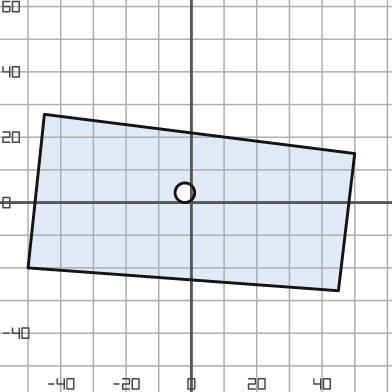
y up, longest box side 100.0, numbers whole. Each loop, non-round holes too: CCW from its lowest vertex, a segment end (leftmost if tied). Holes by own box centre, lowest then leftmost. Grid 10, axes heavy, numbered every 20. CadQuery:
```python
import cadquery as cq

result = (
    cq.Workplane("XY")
    .moveTo(45.0, -27.0)
    .lineTo(50.0, 15.0)
    .lineTo(-45.0, 27.0)
    .lineTo(-50.0, -20.0)
    .close()
    .moveTo(-2.0, 3.0)
    .circle(3.0)
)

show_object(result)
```